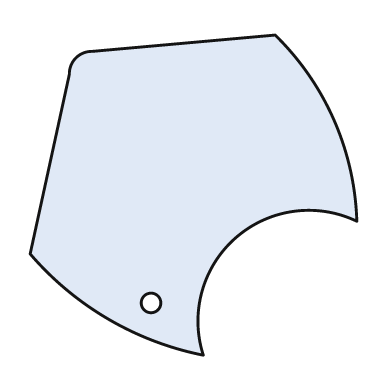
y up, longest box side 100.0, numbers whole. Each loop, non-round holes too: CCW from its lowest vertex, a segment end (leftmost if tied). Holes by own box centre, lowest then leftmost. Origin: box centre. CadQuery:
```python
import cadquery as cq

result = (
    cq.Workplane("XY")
    .moveTo(3.0, -49.0)
    .threePointArc((13.0, -13.0), (50.0, -8.0))
    .threePointArc((43.0, 23.0), (25.0, 49.0))
    .lineTo(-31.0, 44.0)
    .threePointArc((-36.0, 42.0), (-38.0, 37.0))
    .lineTo(-50.0, -18.0)
    .threePointArc((-26.0, -38.0), (3.0, -49.0))
    .close()
    .moveTo(-13.0, -33.0)
    .circle(3.0)
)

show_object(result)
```